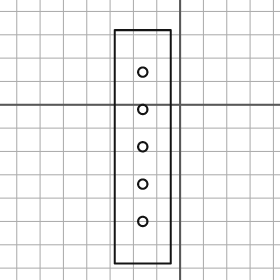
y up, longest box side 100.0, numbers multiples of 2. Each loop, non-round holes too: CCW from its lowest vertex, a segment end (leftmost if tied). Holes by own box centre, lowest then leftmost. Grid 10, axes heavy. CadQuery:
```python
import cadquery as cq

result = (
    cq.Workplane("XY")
    .moveTo(-28.0, -68.0)
    .lineTo(-4.0, -68.0)
    .lineTo(-4.0, 32.0)
    .lineTo(-28.0, 32.0)
    .close()
    .moveTo(-16.0, -50.0)
    .circle(2.0)
    .moveTo(-16.0, -34.0)
    .circle(2.0)
    .moveTo(-16.0, -18.0)
    .circle(2.0)
    .moveTo(-16.0, -2.0)
    .circle(2.0)
    .moveTo(-16.0, 14.0)
    .circle(2.0)
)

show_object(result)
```